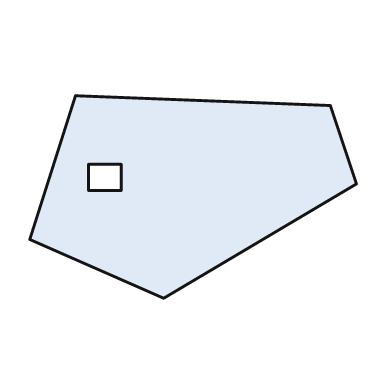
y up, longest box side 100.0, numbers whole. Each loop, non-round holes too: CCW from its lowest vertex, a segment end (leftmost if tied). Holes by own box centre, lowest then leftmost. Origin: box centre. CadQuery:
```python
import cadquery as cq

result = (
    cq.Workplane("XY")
    .moveTo(-9.0, -31.0)
    .lineTo(50.0, 4.0)
    .lineTo(42.0, 28.0)
    .lineTo(-36.0, 31.0)
    .lineTo(-50.0, -13.0)
    .close()
    .moveTo(-32.0, 2.0)
    .lineTo(-22.0, 2.0)
    .lineTo(-22.0, 10.0)
    .lineTo(-32.0, 10.0)
    .close()
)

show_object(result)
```